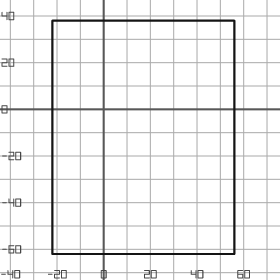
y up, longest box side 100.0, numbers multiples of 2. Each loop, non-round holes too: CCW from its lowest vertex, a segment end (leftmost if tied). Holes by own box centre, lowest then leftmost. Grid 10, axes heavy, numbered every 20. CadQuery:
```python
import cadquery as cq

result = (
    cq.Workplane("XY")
    .moveTo(-22.0, -62.0)
    .lineTo(56.0, -62.0)
    .lineTo(56.0, 38.0)
    .lineTo(-22.0, 38.0)
    .close()
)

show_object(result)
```